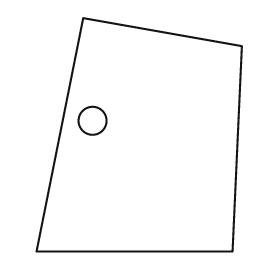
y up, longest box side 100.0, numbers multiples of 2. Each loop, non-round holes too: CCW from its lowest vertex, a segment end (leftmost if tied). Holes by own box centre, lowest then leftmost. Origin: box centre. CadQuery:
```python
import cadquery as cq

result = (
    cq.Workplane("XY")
    .moveTo(-44.0, -50.0)
    .lineTo(40.0, -50.0)
    .lineTo(44.0, 38.0)
    .lineTo(-24.0, 50.0)
    .close()
    .moveTo(-20.0, 6.0)
    .circle(6.0)
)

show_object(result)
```